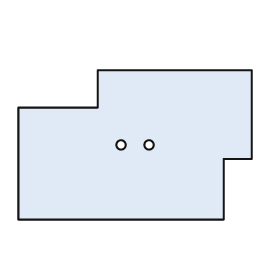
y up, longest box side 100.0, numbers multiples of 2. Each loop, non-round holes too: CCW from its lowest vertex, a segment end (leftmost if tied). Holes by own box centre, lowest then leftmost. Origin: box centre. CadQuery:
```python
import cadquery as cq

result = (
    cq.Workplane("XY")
    .moveTo(-50.0, -32.0)
    .lineTo(38.0, -32.0)
    .lineTo(38.0, -6.0)
    .lineTo(50.0, -6.0)
    .lineTo(50.0, 32.0)
    .lineTo(-16.0, 32.0)
    .lineTo(-16.0, 16.0)
    .lineTo(-50.0, 16.0)
    .close()
    .moveTo(-6.0, 0.0)
    .circle(2.0)
    .moveTo(6.0, 0.0)
    .circle(2.0)
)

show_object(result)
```